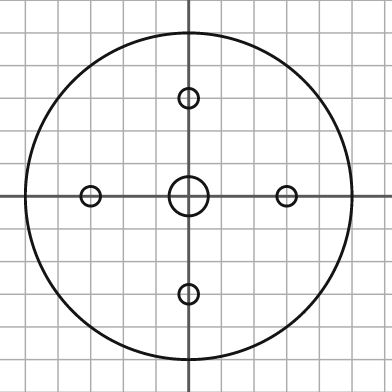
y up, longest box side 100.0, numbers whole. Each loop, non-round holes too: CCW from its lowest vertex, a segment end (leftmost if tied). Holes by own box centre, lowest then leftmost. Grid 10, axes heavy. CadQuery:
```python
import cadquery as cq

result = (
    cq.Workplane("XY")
    .moveTo(0.0, 0.0)
    .circle(50.0)
    .moveTo(0.0, -30.0)
    .circle(3.0)
    .moveTo(-30.0, 0.0)
    .circle(3.0)
    .moveTo(0.0, 0.0)
    .circle(6.0)
    .moveTo(30.0, 0.0)
    .circle(3.0)
    .moveTo(0.0, 30.0)
    .circle(3.0)
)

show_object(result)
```